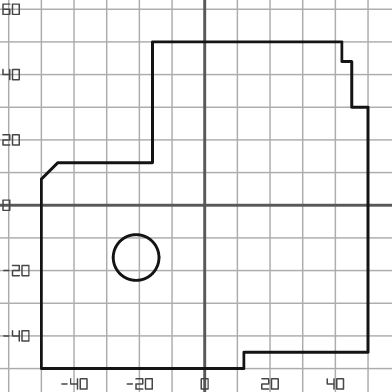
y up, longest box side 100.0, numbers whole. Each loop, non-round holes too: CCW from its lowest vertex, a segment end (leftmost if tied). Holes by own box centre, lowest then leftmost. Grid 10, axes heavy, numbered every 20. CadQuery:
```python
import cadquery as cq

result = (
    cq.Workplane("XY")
    .moveTo(-50.0, -50.0)
    .lineTo(12.0, -50.0)
    .lineTo(12.0, -45.0)
    .lineTo(50.0, -45.0)
    .lineTo(50.0, 30.0)
    .lineTo(45.0, 30.0)
    .lineTo(45.0, 44.0)
    .lineTo(42.0, 44.0)
    .lineTo(42.0, 50.0)
    .lineTo(-16.0, 50.0)
    .lineTo(-16.0, 13.0)
    .lineTo(-45.0, 13.0)
    .lineTo(-50.0, 8.0)
    .close()
    .moveTo(-21.0, -16.0)
    .circle(7.0)
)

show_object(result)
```